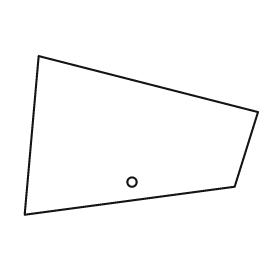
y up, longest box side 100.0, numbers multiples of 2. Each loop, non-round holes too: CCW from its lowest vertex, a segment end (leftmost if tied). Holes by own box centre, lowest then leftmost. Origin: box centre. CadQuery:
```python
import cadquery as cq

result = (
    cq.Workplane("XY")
    .moveTo(-50.0, -34.0)
    .lineTo(40.0, -22.0)
    .lineTo(50.0, 10.0)
    .lineTo(-44.0, 34.0)
    .close()
    .moveTo(-4.0, -20.0)
    .circle(2.0)
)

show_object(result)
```